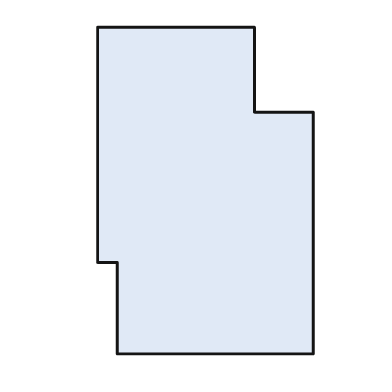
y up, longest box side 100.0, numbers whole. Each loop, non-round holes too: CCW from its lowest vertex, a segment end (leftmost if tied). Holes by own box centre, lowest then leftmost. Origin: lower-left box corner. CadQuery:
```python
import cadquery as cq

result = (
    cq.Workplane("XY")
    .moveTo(6.0, 0.0)
    .lineTo(66.0, 0.0)
    .lineTo(66.0, 74.0)
    .lineTo(48.0, 74.0)
    .lineTo(48.0, 100.0)
    .lineTo(0.0, 100.0)
    .lineTo(0.0, 28.0)
    .lineTo(6.0, 28.0)
    .close()
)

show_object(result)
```